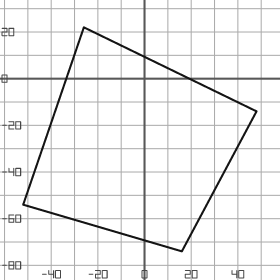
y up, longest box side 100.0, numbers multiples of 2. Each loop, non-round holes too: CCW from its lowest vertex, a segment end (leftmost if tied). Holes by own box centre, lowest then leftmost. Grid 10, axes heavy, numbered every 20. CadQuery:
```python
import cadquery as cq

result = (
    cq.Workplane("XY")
    .moveTo(16.0, -74.0)
    .lineTo(48.0, -14.0)
    .lineTo(-26.0, 22.0)
    .lineTo(-52.0, -54.0)
    .close()
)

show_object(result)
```